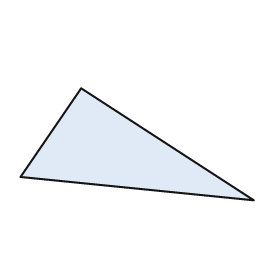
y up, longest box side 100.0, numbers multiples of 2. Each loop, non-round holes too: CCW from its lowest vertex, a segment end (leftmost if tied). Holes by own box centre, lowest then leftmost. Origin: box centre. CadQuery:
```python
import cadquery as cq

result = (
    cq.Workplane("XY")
    .moveTo(50.0, -24.0)
    .lineTo(-24.0, 24.0)
    .lineTo(-50.0, -14.0)
    .close()
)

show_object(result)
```